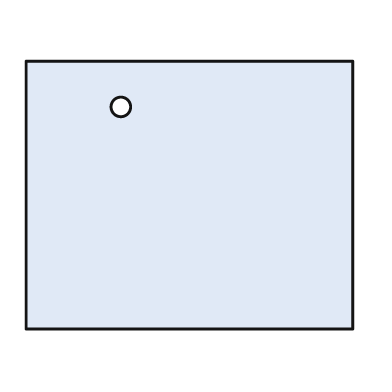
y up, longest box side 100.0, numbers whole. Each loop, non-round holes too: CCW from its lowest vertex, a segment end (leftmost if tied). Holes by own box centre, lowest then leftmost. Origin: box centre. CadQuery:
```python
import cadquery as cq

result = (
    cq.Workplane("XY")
    .moveTo(-50.0, -41.0)
    .lineTo(50.0, -41.0)
    .lineTo(50.0, 41.0)
    .lineTo(-50.0, 41.0)
    .close()
    .moveTo(-21.0, 27.0)
    .circle(3.0)
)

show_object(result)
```